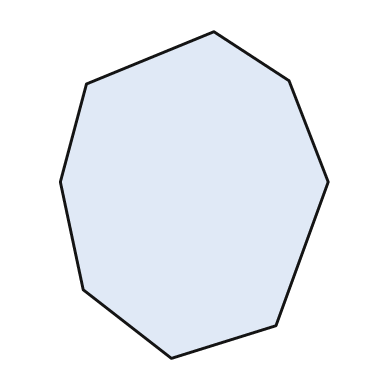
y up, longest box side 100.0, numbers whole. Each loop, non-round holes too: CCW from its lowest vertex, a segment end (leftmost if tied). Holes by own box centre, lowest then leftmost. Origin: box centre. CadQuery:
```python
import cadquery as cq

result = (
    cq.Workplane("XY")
    .moveTo(-7.0, -50.0)
    .lineTo(25.0, -40.0)
    .lineTo(41.0, 4.0)
    .lineTo(29.0, 35.0)
    .lineTo(6.0, 50.0)
    .lineTo(-33.0, 34.0)
    .lineTo(-41.0, 4.0)
    .lineTo(-34.0, -29.0)
    .close()
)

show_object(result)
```